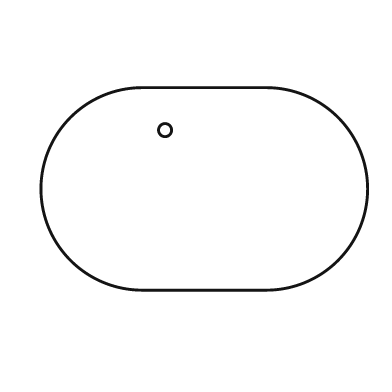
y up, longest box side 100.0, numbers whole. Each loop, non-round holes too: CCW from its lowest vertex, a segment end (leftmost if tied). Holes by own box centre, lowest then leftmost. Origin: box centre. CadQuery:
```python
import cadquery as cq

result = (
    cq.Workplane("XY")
    .moveTo(-19.0, -31.0)
    .lineTo(19.0, -31.0)
    .threePointArc((50.0, 0.0), (19.0, 31.0))
    .lineTo(-19.0, 31.0)
    .threePointArc((-50.0, 0.0), (-19.0, -31.0))
    .close()
    .moveTo(-12.0, 18.0)
    .circle(2.0)
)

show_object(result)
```